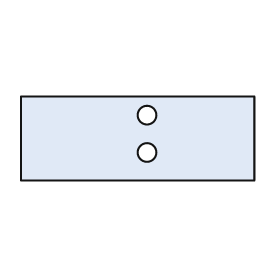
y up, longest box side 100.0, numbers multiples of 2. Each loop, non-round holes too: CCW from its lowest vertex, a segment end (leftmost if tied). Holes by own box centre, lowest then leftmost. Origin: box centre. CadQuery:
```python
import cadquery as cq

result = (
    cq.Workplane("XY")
    .moveTo(-50.0, -18.0)
    .lineTo(50.0, -18.0)
    .lineTo(50.0, 18.0)
    .lineTo(-50.0, 18.0)
    .close()
    .moveTo(4.0, -6.0)
    .circle(4.0)
    .moveTo(4.0, 10.0)
    .circle(4.0)
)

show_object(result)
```